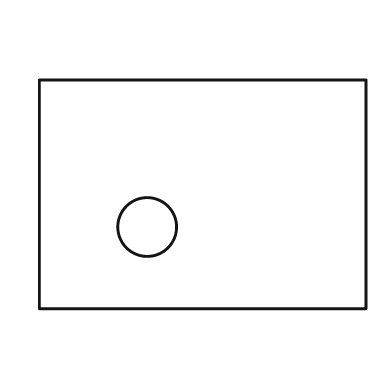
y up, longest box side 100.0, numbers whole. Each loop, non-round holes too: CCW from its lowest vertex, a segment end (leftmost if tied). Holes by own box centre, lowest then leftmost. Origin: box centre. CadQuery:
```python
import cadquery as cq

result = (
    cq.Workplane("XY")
    .moveTo(-50.0, -35.0)
    .lineTo(50.0, -35.0)
    .lineTo(50.0, 35.0)
    .lineTo(-50.0, 35.0)
    .close()
    .moveTo(-17.0, -10.0)
    .circle(9.0)
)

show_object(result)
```